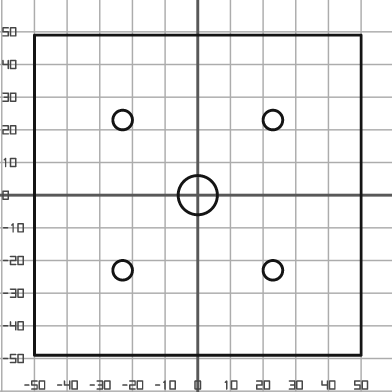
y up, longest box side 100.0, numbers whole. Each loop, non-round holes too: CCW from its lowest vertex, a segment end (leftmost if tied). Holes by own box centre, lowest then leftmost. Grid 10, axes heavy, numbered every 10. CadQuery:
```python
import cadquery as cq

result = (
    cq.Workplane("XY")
    .moveTo(-50.0, -49.0)
    .lineTo(50.0, -49.0)
    .lineTo(50.0, 49.0)
    .lineTo(-50.0, 49.0)
    .close()
    .moveTo(-23.0, -23.0)
    .circle(3.0)
    .moveTo(23.0, -23.0)
    .circle(3.0)
    .moveTo(0.0, 0.0)
    .circle(6.0)
    .moveTo(-23.0, 23.0)
    .circle(3.0)
    .moveTo(23.0, 23.0)
    .circle(3.0)
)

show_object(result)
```